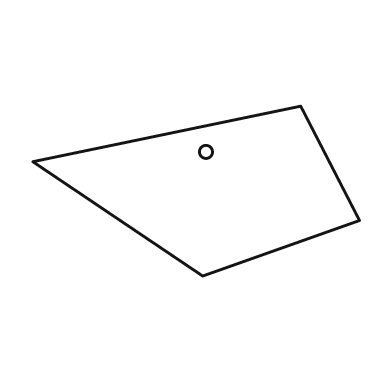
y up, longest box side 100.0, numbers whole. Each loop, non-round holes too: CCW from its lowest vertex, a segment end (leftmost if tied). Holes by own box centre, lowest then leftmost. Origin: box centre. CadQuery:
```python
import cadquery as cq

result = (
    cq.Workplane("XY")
    .moveTo(2.0, -26.0)
    .lineTo(50.0, -9.0)
    .lineTo(32.0, 26.0)
    .lineTo(-50.0, 9.0)
    .close()
    .moveTo(3.0, 12.0)
    .circle(2.0)
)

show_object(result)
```